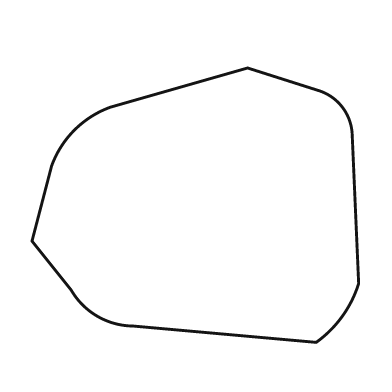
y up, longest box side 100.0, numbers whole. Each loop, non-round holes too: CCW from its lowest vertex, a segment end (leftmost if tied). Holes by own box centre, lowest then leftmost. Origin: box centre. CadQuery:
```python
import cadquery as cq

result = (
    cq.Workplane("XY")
    .moveTo(37.0, -42.0)
    .threePointArc((45.0, -34.0), (50.0, -24.0))
    .lineTo(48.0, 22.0)
    .threePointArc((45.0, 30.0), (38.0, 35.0))
    .lineTo(16.0, 42.0)
    .lineTo(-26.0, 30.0)
    .threePointArc((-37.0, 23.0), (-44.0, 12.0))
    .lineTo(-50.0, -11.0)
    .lineTo(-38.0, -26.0)
    .threePointArc((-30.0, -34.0), (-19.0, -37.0))
    .close()
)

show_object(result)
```